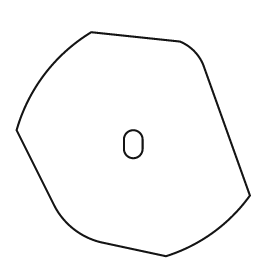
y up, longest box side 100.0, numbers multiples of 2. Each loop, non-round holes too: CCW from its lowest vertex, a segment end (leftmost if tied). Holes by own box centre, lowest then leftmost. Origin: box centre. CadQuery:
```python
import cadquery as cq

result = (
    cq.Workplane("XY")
    .moveTo(14.0, -48.0)
    .threePointArc((34.0, -38.0), (50.0, -22.0))
    .lineTo(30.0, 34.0)
    .threePointArc((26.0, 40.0), (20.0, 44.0))
    .lineTo(-18.0, 48.0)
    .threePointArc((-38.0, 30.0), (-50.0, 6.0))
    .lineTo(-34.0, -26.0)
    .threePointArc((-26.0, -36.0), (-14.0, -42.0))
    .close()
    .moveTo(-4.0, -2.0)
    .threePointArc((0.0, -6.0), (4.0, -2.0))
    .lineTo(4.0, 2.0)
    .threePointArc((0.0, 6.0), (-4.0, 2.0))
    .close()
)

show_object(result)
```